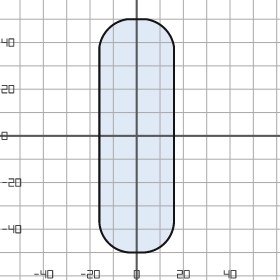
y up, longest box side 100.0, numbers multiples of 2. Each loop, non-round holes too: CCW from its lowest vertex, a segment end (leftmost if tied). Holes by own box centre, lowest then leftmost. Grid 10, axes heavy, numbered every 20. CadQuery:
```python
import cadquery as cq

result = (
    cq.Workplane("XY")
    .moveTo(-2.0, -50.0)
    .lineTo(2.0, -50.0)
    .threePointArc((12.0, -46.0), (16.0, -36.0))
    .lineTo(16.0, 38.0)
    .threePointArc((12.0, 46.0), (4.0, 50.0))
    .lineTo(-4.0, 50.0)
    .threePointArc((-12.0, 46.0), (-16.0, 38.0))
    .lineTo(-16.0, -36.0)
    .threePointArc((-12.0, -46.0), (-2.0, -50.0))
    .close()
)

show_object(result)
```